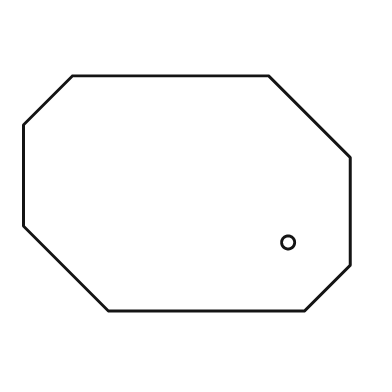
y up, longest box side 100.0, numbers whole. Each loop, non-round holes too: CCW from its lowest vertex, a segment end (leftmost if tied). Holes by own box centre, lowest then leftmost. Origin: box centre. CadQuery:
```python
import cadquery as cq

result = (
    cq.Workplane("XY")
    .moveTo(-24.0, -36.0)
    .lineTo(36.0, -36.0)
    .lineTo(50.0, -22.0)
    .lineTo(50.0, 11.0)
    .lineTo(25.0, 36.0)
    .lineTo(-35.0, 36.0)
    .lineTo(-50.0, 21.0)
    .lineTo(-50.0, -10.0)
    .close()
    .moveTo(31.0, -15.0)
    .circle(2.0)
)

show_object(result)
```